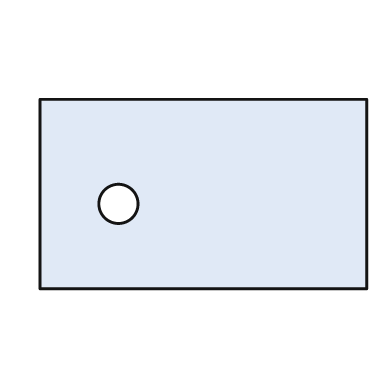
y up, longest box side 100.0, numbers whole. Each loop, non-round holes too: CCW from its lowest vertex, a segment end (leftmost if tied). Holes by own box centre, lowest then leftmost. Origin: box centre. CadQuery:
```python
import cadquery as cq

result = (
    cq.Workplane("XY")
    .moveTo(-50.0, -29.0)
    .lineTo(50.0, -29.0)
    .lineTo(50.0, 29.0)
    .lineTo(-50.0, 29.0)
    .close()
    .moveTo(-26.0, -3.0)
    .circle(6.0)
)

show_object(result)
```